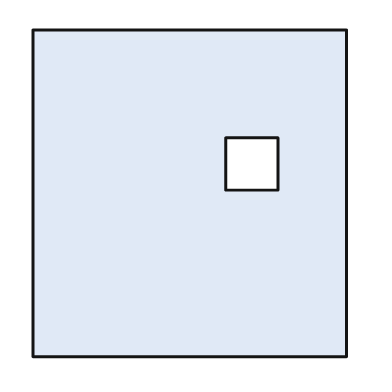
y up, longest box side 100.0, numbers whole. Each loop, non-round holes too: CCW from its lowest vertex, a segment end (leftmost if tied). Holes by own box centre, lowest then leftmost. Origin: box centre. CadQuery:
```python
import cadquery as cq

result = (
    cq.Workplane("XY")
    .moveTo(-48.0, -50.0)
    .lineTo(48.0, -50.0)
    .lineTo(48.0, 50.0)
    .lineTo(-48.0, 50.0)
    .close()
    .moveTo(11.0, 1.0)
    .lineTo(27.0, 1.0)
    .lineTo(27.0, 17.0)
    .lineTo(11.0, 17.0)
    .close()
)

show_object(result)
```